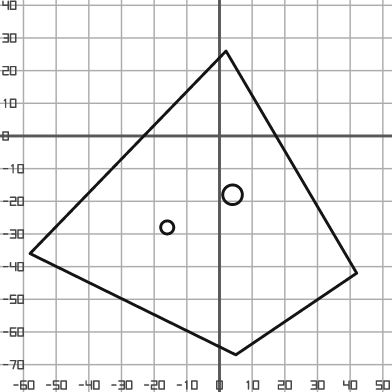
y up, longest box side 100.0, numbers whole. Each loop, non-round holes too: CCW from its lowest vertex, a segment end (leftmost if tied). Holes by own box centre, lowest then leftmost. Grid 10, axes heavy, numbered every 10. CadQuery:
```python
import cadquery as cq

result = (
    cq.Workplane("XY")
    .moveTo(5.0, -67.0)
    .lineTo(42.0, -42.0)
    .lineTo(2.0, 26.0)
    .lineTo(-58.0, -36.0)
    .close()
    .moveTo(-16.0, -28.0)
    .circle(2.0)
    .moveTo(4.0, -18.0)
    .circle(3.0)
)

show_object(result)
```